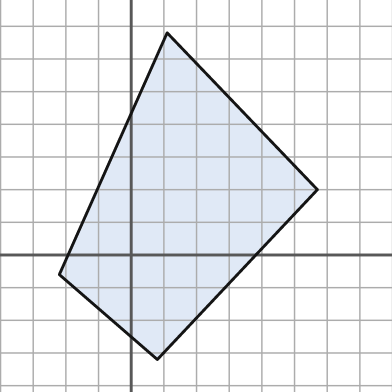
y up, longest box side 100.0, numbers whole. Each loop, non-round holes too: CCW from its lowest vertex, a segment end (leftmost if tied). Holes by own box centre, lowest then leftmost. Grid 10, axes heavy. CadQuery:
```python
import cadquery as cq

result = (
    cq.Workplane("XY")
    .moveTo(8.0, -32.0)
    .lineTo(57.0, 20.0)
    .lineTo(11.0, 68.0)
    .lineTo(-22.0, -6.0)
    .close()
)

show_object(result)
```